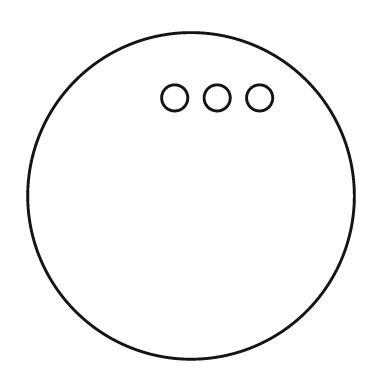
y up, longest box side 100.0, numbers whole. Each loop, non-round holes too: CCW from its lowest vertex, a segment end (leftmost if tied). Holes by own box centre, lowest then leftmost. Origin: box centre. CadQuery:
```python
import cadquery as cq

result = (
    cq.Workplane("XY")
    .moveTo(0.0, 0.0)
    .circle(50.0)
    .moveTo(-5.0, 30.0)
    .circle(4.0)
    .moveTo(8.0, 30.0)
    .circle(4.0)
    .moveTo(21.0, 30.0)
    .circle(4.0)
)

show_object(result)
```